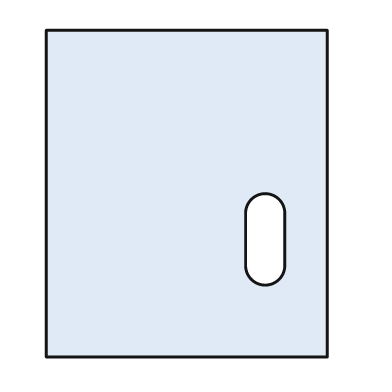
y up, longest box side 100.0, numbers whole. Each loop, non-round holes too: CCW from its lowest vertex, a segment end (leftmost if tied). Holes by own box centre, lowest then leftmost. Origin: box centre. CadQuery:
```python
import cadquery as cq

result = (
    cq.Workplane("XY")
    .moveTo(-43.0, -50.0)
    .lineTo(43.0, -50.0)
    .lineTo(43.0, 50.0)
    .lineTo(-43.0, 50.0)
    .close()
    .moveTo(18.0, -22.0)
    .threePointArc((24.0, -28.0), (30.0, -22.0))
    .lineTo(30.0, -6.0)
    .threePointArc((24.0, 0.0), (18.0, -6.0))
    .close()
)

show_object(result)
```